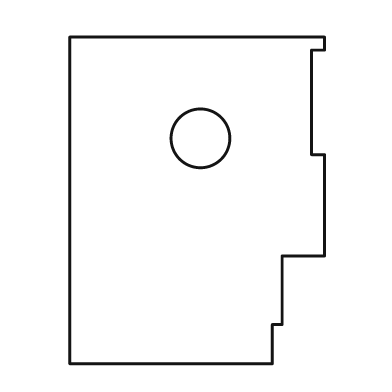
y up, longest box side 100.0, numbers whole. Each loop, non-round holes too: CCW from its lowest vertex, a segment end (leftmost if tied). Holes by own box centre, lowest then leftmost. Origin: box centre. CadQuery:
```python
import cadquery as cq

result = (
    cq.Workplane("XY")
    .moveTo(-39.0, -50.0)
    .lineTo(23.0, -50.0)
    .lineTo(23.0, -38.0)
    .lineTo(26.0, -38.0)
    .lineTo(26.0, -17.0)
    .lineTo(39.0, -17.0)
    .lineTo(39.0, 14.0)
    .lineTo(35.0, 14.0)
    .lineTo(35.0, 46.0)
    .lineTo(39.0, 46.0)
    .lineTo(39.0, 50.0)
    .lineTo(-39.0, 50.0)
    .close()
    .moveTo(1.0, 19.0)
    .circle(9.0)
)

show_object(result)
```